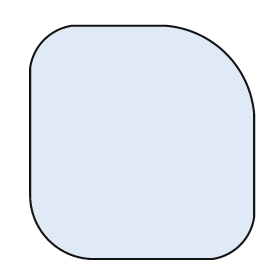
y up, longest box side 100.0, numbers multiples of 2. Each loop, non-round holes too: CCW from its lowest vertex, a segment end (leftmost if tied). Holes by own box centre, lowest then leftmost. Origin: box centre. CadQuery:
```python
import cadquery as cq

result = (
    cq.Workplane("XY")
    .moveTo(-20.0, -50.0)
    .lineTo(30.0, -50.0)
    .threePointArc((42.0, -44.0), (48.0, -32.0))
    .lineTo(48.0, 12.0)
    .threePointArc((36.0, 38.0), (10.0, 50.0))
    .lineTo(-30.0, 50.0)
    .threePointArc((-42.0, 44.0), (-48.0, 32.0))
    .lineTo(-48.0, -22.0)
    .threePointArc((-40.0, -42.0), (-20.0, -50.0))
    .close()
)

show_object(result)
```